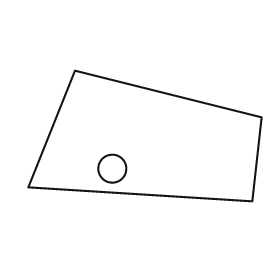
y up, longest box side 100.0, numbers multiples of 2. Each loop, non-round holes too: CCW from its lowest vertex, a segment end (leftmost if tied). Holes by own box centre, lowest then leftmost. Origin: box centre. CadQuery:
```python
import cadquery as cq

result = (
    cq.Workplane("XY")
    .moveTo(46.0, -28.0)
    .lineTo(50.0, 8.0)
    .lineTo(-30.0, 28.0)
    .lineTo(-50.0, -22.0)
    .close()
    .moveTo(-14.0, -14.0)
    .circle(6.0)
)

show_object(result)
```